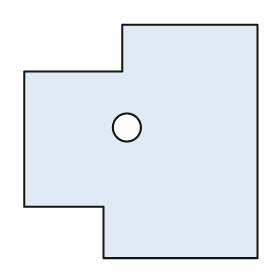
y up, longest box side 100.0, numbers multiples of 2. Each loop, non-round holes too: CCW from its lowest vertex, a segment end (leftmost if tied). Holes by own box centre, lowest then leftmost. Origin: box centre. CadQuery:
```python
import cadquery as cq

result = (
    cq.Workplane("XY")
    .moveTo(-16.0, -50.0)
    .lineTo(50.0, -50.0)
    .lineTo(50.0, 50.0)
    .lineTo(-8.0, 50.0)
    .lineTo(-8.0, 30.0)
    .lineTo(-50.0, 30.0)
    .lineTo(-50.0, -28.0)
    .lineTo(-16.0, -28.0)
    .close()
    .moveTo(-6.0, 6.0)
    .circle(6.0)
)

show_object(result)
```